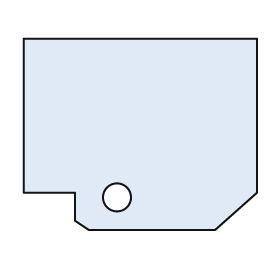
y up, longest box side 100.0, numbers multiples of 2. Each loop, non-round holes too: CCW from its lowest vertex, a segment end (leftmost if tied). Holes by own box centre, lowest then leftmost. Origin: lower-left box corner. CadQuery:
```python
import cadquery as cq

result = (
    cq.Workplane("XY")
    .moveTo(28.0, 0.0)
    .lineTo(82.0, 0.0)
    .lineTo(100.0, 16.0)
    .lineTo(100.0, 82.0)
    .lineTo(0.0, 82.0)
    .lineTo(0.0, 16.0)
    .lineTo(22.0, 16.0)
    .lineTo(22.0, 4.0)
    .close()
    .moveTo(40.0, 14.0)
    .circle(6.0)
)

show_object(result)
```